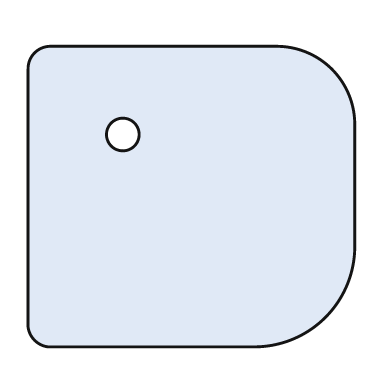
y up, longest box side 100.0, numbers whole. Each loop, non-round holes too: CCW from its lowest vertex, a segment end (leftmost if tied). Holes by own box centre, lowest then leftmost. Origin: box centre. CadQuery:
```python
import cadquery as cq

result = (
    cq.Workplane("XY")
    .moveTo(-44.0, -46.0)
    .lineTo(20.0, -46.0)
    .threePointArc((41.0, -37.0), (50.0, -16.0))
    .lineTo(50.0, 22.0)
    .threePointArc((43.0, 39.0), (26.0, 46.0))
    .lineTo(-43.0, 46.0)
    .threePointArc((-48.0, 44.0), (-50.0, 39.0))
    .lineTo(-50.0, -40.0)
    .threePointArc((-48.0, -44.0), (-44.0, -46.0))
    .close()
    .moveTo(-21.0, 19.0)
    .circle(5.0)
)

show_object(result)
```